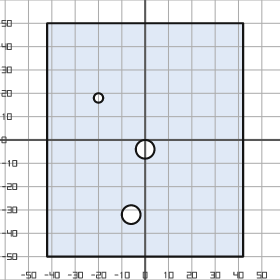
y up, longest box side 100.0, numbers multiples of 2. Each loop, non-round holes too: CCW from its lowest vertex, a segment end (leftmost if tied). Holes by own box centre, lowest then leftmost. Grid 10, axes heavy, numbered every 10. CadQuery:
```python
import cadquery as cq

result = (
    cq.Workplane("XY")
    .moveTo(-42.0, -50.0)
    .lineTo(42.0, -50.0)
    .lineTo(42.0, 50.0)
    .lineTo(-42.0, 50.0)
    .close()
    .moveTo(-6.0, -32.0)
    .circle(4.0)
    .moveTo(0.0, -4.0)
    .circle(4.0)
    .moveTo(-20.0, 18.0)
    .circle(2.0)
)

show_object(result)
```